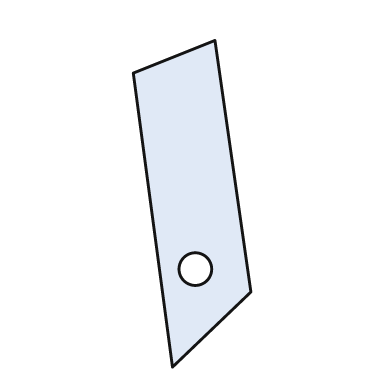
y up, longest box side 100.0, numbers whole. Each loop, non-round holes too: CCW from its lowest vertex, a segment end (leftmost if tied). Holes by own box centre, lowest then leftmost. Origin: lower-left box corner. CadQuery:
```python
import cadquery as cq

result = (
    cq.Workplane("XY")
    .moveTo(12.0, 0.0)
    .lineTo(36.0, 23.0)
    .lineTo(25.0, 100.0)
    .lineTo(0.0, 90.0)
    .close()
    .moveTo(19.0, 30.0)
    .circle(5.0)
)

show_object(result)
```